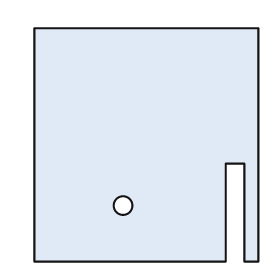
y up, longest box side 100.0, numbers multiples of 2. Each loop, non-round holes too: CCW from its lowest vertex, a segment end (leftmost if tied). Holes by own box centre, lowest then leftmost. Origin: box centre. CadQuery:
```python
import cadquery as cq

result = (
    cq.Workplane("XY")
    .moveTo(-48.0, -50.0)
    .lineTo(34.0, -50.0)
    .lineTo(34.0, -8.0)
    .lineTo(42.0, -8.0)
    .lineTo(42.0, -50.0)
    .lineTo(48.0, -50.0)
    .lineTo(48.0, 50.0)
    .lineTo(-48.0, 50.0)
    .close()
    .moveTo(-10.0, -26.0)
    .circle(4.0)
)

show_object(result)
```